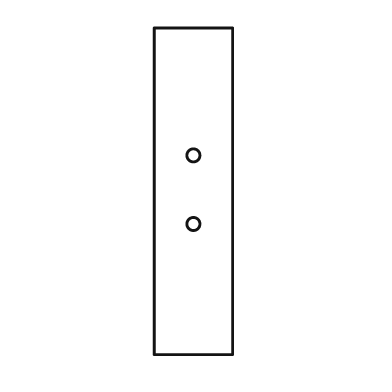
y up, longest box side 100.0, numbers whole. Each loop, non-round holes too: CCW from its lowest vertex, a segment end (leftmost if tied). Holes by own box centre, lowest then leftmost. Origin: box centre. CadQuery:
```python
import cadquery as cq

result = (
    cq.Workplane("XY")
    .moveTo(-12.0, -50.0)
    .lineTo(12.0, -50.0)
    .lineTo(12.0, 50.0)
    .lineTo(-12.0, 50.0)
    .close()
    .moveTo(0.0, -10.0)
    .circle(2.0)
    .moveTo(0.0, 11.0)
    .circle(2.0)
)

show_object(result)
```